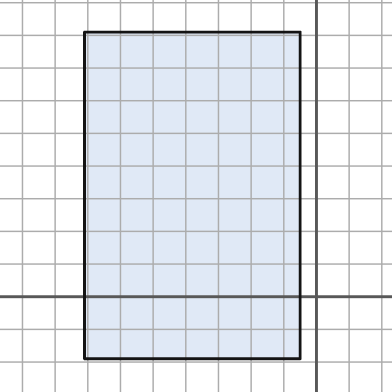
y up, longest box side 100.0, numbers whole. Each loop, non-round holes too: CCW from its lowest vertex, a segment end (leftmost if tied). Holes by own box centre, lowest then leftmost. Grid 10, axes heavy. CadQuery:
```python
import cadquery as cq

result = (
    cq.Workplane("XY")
    .moveTo(-71.0, -19.0)
    .lineTo(-5.0, -19.0)
    .lineTo(-5.0, 81.0)
    .lineTo(-71.0, 81.0)
    .close()
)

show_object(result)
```